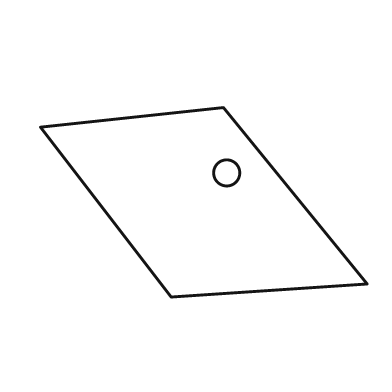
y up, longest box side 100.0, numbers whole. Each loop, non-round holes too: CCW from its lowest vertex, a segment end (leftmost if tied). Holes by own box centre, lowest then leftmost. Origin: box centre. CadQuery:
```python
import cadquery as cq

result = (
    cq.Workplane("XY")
    .moveTo(-10.0, -29.0)
    .lineTo(50.0, -25.0)
    .lineTo(6.0, 29.0)
    .lineTo(-50.0, 23.0)
    .close()
    .moveTo(7.0, 9.0)
    .circle(4.0)
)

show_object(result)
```